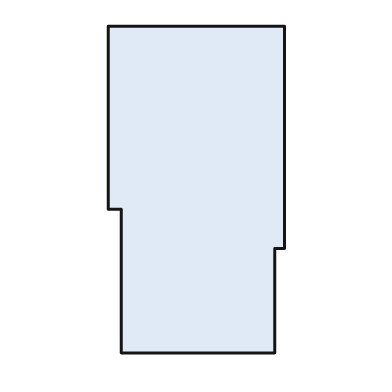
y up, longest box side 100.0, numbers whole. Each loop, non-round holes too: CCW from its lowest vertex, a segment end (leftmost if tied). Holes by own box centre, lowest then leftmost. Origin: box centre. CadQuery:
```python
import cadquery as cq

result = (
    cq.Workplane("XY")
    .moveTo(-23.0, -50.0)
    .lineTo(24.0, -50.0)
    .lineTo(24.0, -18.0)
    .lineTo(27.0, -18.0)
    .lineTo(27.0, 50.0)
    .lineTo(-27.0, 50.0)
    .lineTo(-27.0, -6.0)
    .lineTo(-23.0, -6.0)
    .close()
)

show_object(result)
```